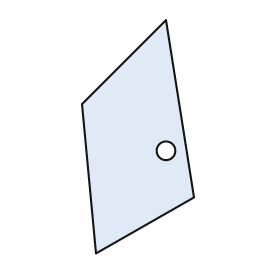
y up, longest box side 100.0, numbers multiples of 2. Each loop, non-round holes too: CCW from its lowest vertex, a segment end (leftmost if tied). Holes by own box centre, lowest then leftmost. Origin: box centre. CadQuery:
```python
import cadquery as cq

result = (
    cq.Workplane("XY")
    .moveTo(-18.0, -50.0)
    .lineTo(24.0, -26.0)
    .lineTo(12.0, 50.0)
    .lineTo(-24.0, 14.0)
    .close()
    .moveTo(12.0, -6.0)
    .circle(4.0)
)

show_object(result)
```